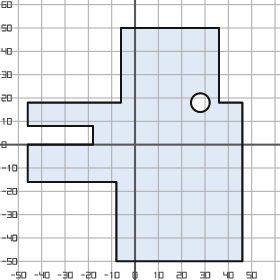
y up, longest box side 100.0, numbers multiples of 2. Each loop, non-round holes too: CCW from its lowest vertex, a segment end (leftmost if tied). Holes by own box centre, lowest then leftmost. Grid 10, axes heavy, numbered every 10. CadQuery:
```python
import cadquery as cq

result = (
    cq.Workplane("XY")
    .moveTo(-8.0, -50.0)
    .lineTo(46.0, -50.0)
    .lineTo(46.0, 18.0)
    .lineTo(36.0, 18.0)
    .lineTo(36.0, 50.0)
    .lineTo(-6.0, 50.0)
    .lineTo(-6.0, 18.0)
    .lineTo(-46.0, 18.0)
    .lineTo(-46.0, 8.0)
    .lineTo(-18.0, 8.0)
    .lineTo(-18.0, 0.0)
    .lineTo(-46.0, 0.0)
    .lineTo(-46.0, -16.0)
    .lineTo(-8.0, -16.0)
    .close()
    .moveTo(28.0, 18.0)
    .circle(4.0)
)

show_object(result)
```